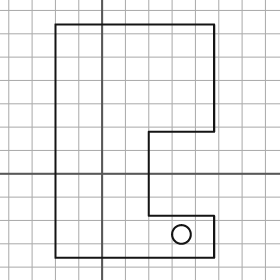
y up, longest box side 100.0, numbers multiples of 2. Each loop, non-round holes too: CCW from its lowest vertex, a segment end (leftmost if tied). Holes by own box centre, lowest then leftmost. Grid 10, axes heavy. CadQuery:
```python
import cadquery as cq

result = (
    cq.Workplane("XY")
    .moveTo(-20.0, -36.0)
    .lineTo(48.0, -36.0)
    .lineTo(48.0, -18.0)
    .lineTo(20.0, -18.0)
    .lineTo(20.0, 18.0)
    .lineTo(48.0, 18.0)
    .lineTo(48.0, 64.0)
    .lineTo(-20.0, 64.0)
    .close()
    .moveTo(34.0, -26.0)
    .circle(4.0)
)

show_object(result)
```